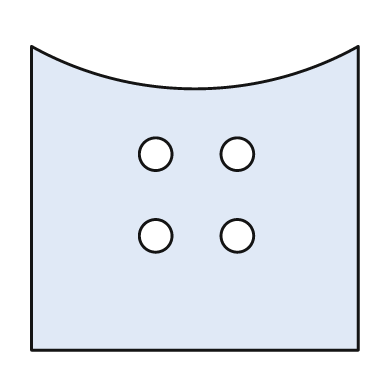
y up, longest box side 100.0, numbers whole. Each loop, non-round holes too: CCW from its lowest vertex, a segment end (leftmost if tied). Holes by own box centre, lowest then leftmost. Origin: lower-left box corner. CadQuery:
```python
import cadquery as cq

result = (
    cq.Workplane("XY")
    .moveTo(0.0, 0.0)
    .lineTo(100.0, 0.0)
    .lineTo(100.0, 93.0)
    .threePointArc((50.0, 80.0), (0.0, 93.0))
    .close()
    .moveTo(38.0, 35.0)
    .circle(5.0)
    .moveTo(63.0, 35.0)
    .circle(5.0)
    .moveTo(38.0, 60.0)
    .circle(5.0)
    .moveTo(63.0, 60.0)
    .circle(5.0)
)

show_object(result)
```